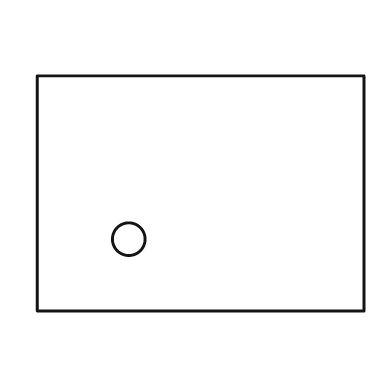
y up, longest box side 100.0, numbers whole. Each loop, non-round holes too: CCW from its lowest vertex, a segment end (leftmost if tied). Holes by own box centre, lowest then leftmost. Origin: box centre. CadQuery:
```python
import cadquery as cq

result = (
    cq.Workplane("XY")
    .moveTo(-50.0, -36.0)
    .lineTo(50.0, -36.0)
    .lineTo(50.0, 36.0)
    .lineTo(-50.0, 36.0)
    .close()
    .moveTo(-22.0, -14.0)
    .circle(5.0)
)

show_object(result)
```